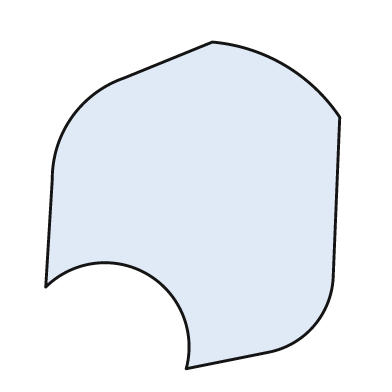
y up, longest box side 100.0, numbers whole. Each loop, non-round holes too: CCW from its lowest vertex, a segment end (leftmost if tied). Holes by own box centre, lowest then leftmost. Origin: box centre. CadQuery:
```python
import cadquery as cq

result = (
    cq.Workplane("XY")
    .moveTo(-2.0, -50.0)
    .lineTo(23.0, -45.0)
    .threePointArc((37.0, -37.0), (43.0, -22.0))
    .lineTo(45.0, 27.0)
    .threePointArc((28.0, 43.0), (6.0, 50.0))
    .lineTo(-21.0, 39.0)
    .threePointArc((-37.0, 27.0), (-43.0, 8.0))
    .lineTo(-45.0, -25.0)
    .threePointArc((-14.0, -21.0), (-2.0, -50.0))
    .close()
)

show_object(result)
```